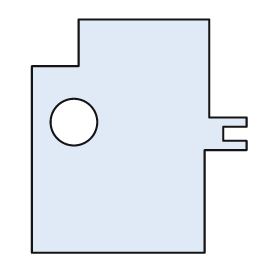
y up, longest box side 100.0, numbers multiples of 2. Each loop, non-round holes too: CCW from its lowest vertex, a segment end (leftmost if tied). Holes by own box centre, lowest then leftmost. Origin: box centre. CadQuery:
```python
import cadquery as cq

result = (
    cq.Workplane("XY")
    .moveTo(-46.0, -50.0)
    .lineTo(28.0, -50.0)
    .lineTo(28.0, -6.0)
    .lineTo(46.0, -6.0)
    .lineTo(46.0, -2.0)
    .lineTo(36.0, -2.0)
    .lineTo(36.0, 4.0)
    .lineTo(46.0, 4.0)
    .lineTo(46.0, 8.0)
    .lineTo(30.0, 8.0)
    .lineTo(30.0, 50.0)
    .lineTo(-26.0, 50.0)
    .lineTo(-26.0, 30.0)
    .lineTo(-46.0, 30.0)
    .close()
    .moveTo(-28.0, 6.0)
    .circle(10.0)
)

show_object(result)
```